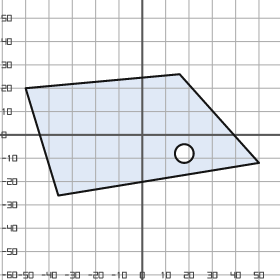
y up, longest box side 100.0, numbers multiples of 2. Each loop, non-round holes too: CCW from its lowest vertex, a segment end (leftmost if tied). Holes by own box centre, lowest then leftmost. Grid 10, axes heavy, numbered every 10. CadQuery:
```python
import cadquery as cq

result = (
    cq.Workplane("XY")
    .moveTo(-36.0, -26.0)
    .lineTo(50.0, -12.0)
    .lineTo(16.0, 26.0)
    .lineTo(-50.0, 20.0)
    .close()
    .moveTo(18.0, -8.0)
    .circle(4.0)
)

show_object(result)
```